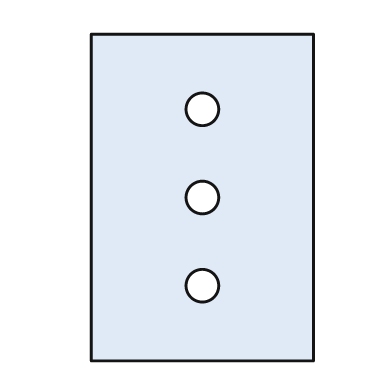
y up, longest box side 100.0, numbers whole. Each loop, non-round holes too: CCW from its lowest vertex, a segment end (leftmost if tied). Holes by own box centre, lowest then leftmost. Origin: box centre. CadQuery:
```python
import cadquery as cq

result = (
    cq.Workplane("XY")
    .moveTo(-34.0, -50.0)
    .lineTo(34.0, -50.0)
    .lineTo(34.0, 50.0)
    .lineTo(-34.0, 50.0)
    .close()
    .moveTo(0.0, -27.0)
    .circle(5.0)
    .moveTo(0.0, 0.0)
    .circle(5.0)
    .moveTo(0.0, 27.0)
    .circle(5.0)
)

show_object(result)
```